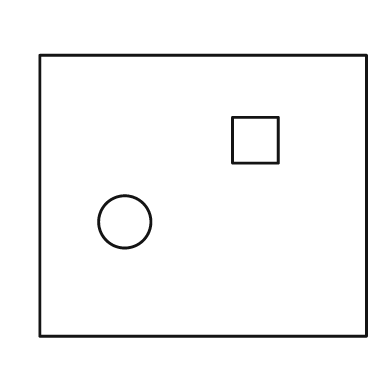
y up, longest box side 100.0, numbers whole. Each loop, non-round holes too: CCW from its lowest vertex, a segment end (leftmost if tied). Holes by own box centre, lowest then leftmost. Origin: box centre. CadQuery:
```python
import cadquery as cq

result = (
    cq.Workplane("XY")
    .moveTo(-50.0, -43.0)
    .lineTo(50.0, -43.0)
    .lineTo(50.0, 43.0)
    .lineTo(-50.0, 43.0)
    .close()
    .moveTo(-24.0, -8.0)
    .circle(8.0)
    .moveTo(9.0, 10.0)
    .lineTo(23.0, 10.0)
    .lineTo(23.0, 24.0)
    .lineTo(9.0, 24.0)
    .close()
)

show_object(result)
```